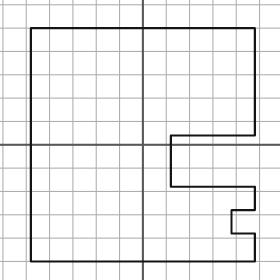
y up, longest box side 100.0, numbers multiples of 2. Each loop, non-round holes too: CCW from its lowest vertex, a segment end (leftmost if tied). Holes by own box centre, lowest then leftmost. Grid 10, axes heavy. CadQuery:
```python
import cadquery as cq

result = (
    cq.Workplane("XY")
    .moveTo(-48.0, -50.0)
    .lineTo(48.0, -50.0)
    .lineTo(48.0, -38.0)
    .lineTo(38.0, -38.0)
    .lineTo(38.0, -28.0)
    .lineTo(48.0, -28.0)
    .lineTo(48.0, -18.0)
    .lineTo(12.0, -18.0)
    .lineTo(12.0, 4.0)
    .lineTo(48.0, 4.0)
    .lineTo(48.0, 50.0)
    .lineTo(-48.0, 50.0)
    .close()
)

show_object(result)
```